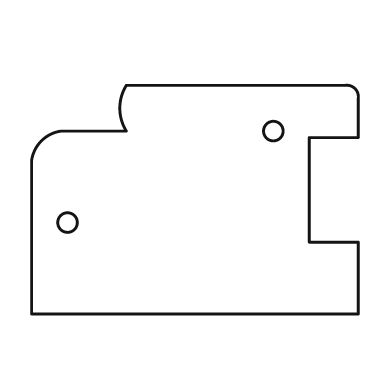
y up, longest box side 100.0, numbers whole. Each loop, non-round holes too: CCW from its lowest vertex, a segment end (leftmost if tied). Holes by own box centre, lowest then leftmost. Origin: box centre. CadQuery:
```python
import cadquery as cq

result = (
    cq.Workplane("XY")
    .moveTo(-50.0, -35.0)
    .lineTo(50.0, -35.0)
    .lineTo(50.0, -13.0)
    .lineTo(35.0, -13.0)
    .lineTo(35.0, 19.0)
    .lineTo(50.0, 19.0)
    .lineTo(50.0, 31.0)
    .threePointArc((49.0, 34.0), (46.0, 35.0))
    .lineTo(-21.0, 35.0)
    .threePointArc((-23.0, 28.0), (-21.0, 21.0))
    .lineTo(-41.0, 21.0)
    .threePointArc((-47.0, 18.0), (-50.0, 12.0))
    .close()
    .moveTo(-39.0, -7.0)
    .circle(3.0)
    .moveTo(24.0, 21.0)
    .circle(3.0)
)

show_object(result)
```